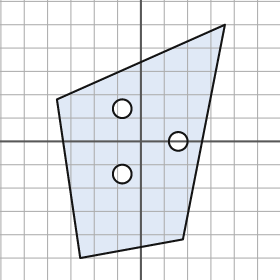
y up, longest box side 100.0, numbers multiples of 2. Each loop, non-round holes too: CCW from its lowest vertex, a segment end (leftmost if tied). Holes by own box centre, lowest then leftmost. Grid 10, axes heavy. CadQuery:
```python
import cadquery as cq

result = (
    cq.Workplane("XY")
    .moveTo(-26.0, -50.0)
    .lineTo(18.0, -42.0)
    .lineTo(36.0, 50.0)
    .lineTo(-36.0, 18.0)
    .close()
    .moveTo(-8.0, -14.0)
    .circle(4.0)
    .moveTo(16.0, 0.0)
    .circle(4.0)
    .moveTo(-8.0, 14.0)
    .circle(4.0)
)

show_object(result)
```